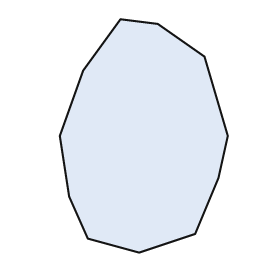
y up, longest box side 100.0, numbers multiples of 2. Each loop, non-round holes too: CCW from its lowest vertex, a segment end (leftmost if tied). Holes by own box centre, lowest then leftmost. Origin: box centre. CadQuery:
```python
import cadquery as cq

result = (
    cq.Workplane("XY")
    .moveTo(-2.0, -50.0)
    .lineTo(22.0, -42.0)
    .lineTo(32.0, -18.0)
    .lineTo(36.0, 0.0)
    .lineTo(26.0, 34.0)
    .lineTo(6.0, 48.0)
    .lineTo(-10.0, 50.0)
    .lineTo(-26.0, 28.0)
    .lineTo(-36.0, 0.0)
    .lineTo(-32.0, -26.0)
    .lineTo(-24.0, -44.0)
    .close()
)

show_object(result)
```